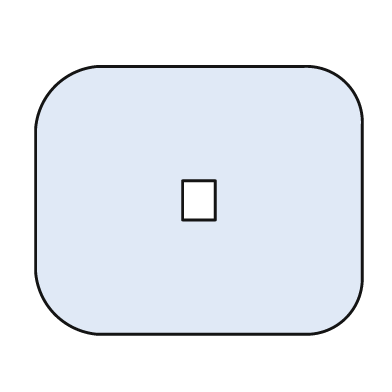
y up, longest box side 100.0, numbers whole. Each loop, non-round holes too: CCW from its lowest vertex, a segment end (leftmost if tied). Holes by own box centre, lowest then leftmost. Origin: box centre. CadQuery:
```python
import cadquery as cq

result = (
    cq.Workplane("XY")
    .moveTo(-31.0, -41.0)
    .lineTo(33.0, -41.0)
    .threePointArc((45.0, -36.0), (50.0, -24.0))
    .lineTo(50.0, 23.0)
    .threePointArc((45.0, 36.0), (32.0, 41.0))
    .lineTo(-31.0, 41.0)
    .threePointArc((-44.0, 35.0), (-50.0, 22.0))
    .lineTo(-50.0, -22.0)
    .threePointArc((-44.0, -35.0), (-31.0, -41.0))
    .close()
    .moveTo(-5.0, -6.0)
    .lineTo(5.0, -6.0)
    .lineTo(5.0, 6.0)
    .lineTo(-5.0, 6.0)
    .close()
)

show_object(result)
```